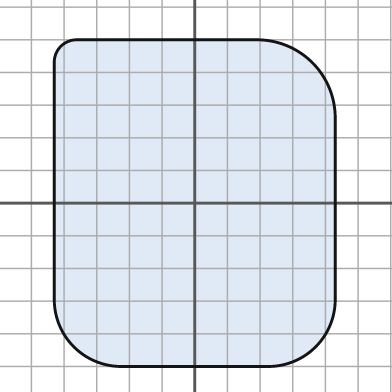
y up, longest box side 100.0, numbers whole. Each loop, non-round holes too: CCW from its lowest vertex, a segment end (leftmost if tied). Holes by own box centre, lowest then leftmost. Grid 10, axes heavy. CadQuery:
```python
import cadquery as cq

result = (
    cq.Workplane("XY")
    .moveTo(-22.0, -50.0)
    .lineTo(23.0, -50.0)
    .threePointArc((37.0, -44.0), (43.0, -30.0))
    .lineTo(43.0, 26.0)
    .threePointArc((36.0, 43.0), (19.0, 50.0))
    .lineTo(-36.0, 50.0)
    .threePointArc((-41.0, 48.0), (-43.0, 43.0))
    .lineTo(-43.0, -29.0)
    .threePointArc((-37.0, -44.0), (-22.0, -50.0))
    .close()
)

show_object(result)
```